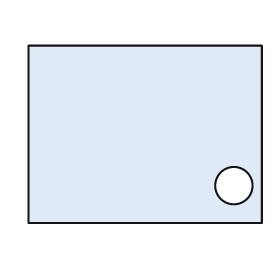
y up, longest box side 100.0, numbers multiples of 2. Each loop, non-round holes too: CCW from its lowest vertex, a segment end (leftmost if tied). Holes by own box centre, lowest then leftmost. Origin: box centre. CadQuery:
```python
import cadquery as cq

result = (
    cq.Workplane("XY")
    .moveTo(-50.0, -38.0)
    .lineTo(50.0, -38.0)
    .lineTo(50.0, 38.0)
    .lineTo(-50.0, 38.0)
    .close()
    .moveTo(38.0, -22.0)
    .circle(8.0)
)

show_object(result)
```